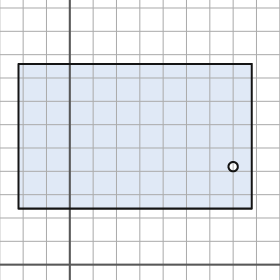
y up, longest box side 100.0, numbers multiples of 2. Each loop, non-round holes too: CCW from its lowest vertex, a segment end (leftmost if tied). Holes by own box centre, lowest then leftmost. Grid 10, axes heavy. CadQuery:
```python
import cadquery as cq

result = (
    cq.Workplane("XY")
    .moveTo(-22.0, 24.0)
    .lineTo(78.0, 24.0)
    .lineTo(78.0, 86.0)
    .lineTo(-22.0, 86.0)
    .close()
    .moveTo(70.0, 42.0)
    .circle(2.0)
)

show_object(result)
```